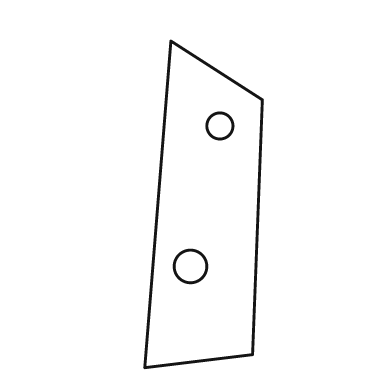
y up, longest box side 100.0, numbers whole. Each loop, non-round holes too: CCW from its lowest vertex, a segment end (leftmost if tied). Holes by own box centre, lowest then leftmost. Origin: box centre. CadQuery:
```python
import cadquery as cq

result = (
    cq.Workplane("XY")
    .moveTo(-18.0, -50.0)
    .lineTo(15.0, -46.0)
    .lineTo(18.0, 32.0)
    .lineTo(-10.0, 50.0)
    .close()
    .moveTo(-4.0, -19.0)
    .circle(5.0)
    .moveTo(5.0, 24.0)
    .circle(4.0)
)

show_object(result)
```